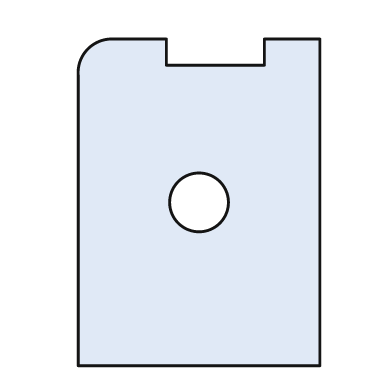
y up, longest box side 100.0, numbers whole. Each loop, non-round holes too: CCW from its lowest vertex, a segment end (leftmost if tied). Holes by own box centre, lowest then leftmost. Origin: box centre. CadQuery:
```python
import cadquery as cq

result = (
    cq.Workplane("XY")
    .moveTo(-37.0, -50.0)
    .lineTo(37.0, -50.0)
    .lineTo(37.0, 50.0)
    .lineTo(20.0, 50.0)
    .lineTo(20.0, 42.0)
    .lineTo(-10.0, 42.0)
    .lineTo(-10.0, 50.0)
    .lineTo(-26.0, 50.0)
    .threePointArc((-34.0, 47.0), (-37.0, 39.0))
    .close()
    .moveTo(0.0, 0.0)
    .circle(9.0)
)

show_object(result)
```